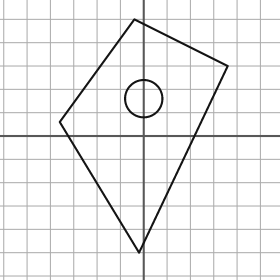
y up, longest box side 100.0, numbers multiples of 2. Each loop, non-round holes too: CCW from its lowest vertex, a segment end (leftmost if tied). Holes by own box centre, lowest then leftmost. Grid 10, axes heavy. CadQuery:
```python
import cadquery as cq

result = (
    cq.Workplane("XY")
    .moveTo(-2.0, -50.0)
    .lineTo(36.0, 30.0)
    .lineTo(-4.0, 50.0)
    .lineTo(-36.0, 6.0)
    .close()
    .moveTo(0.0, 16.0)
    .circle(8.0)
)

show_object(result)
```